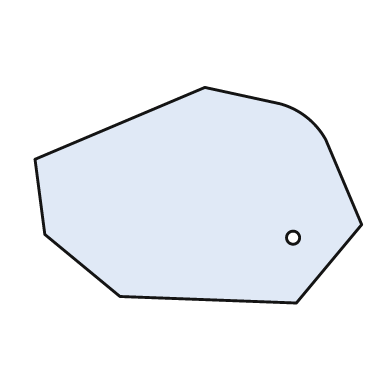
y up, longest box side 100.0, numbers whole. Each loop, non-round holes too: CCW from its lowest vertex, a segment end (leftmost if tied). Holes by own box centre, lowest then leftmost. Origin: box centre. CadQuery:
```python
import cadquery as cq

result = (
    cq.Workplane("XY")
    .moveTo(30.0, -33.0)
    .lineTo(50.0, -9.0)
    .lineTo(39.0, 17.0)
    .threePointArc((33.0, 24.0), (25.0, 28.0))
    .lineTo(2.0, 33.0)
    .lineTo(-50.0, 11.0)
    .lineTo(-47.0, -12.0)
    .lineTo(-24.0, -31.0)
    .close()
    .moveTo(29.0, -13.0)
    .circle(2.0)
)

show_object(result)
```